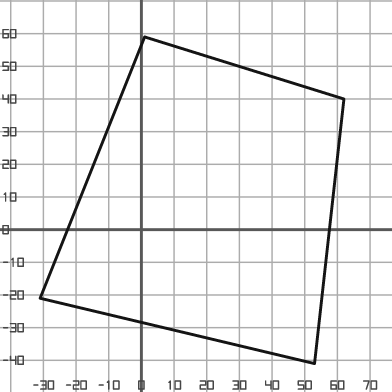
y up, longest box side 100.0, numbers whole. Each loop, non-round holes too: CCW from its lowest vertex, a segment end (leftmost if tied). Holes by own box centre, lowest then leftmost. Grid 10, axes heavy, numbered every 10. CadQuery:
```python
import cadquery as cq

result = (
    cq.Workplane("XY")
    .moveTo(53.0, -41.0)
    .lineTo(62.0, 40.0)
    .lineTo(1.0, 59.0)
    .lineTo(-31.0, -21.0)
    .close()
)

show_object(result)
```